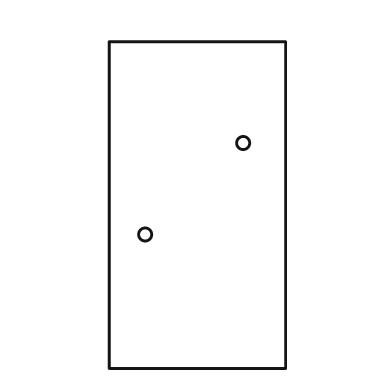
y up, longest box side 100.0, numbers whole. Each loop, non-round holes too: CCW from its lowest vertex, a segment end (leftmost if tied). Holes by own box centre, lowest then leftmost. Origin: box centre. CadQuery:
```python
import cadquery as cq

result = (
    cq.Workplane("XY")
    .moveTo(-27.0, -50.0)
    .lineTo(27.0, -50.0)
    .lineTo(27.0, 50.0)
    .lineTo(-27.0, 50.0)
    .close()
    .moveTo(-16.0, -9.0)
    .circle(2.0)
    .moveTo(14.0, 19.0)
    .circle(2.0)
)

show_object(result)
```